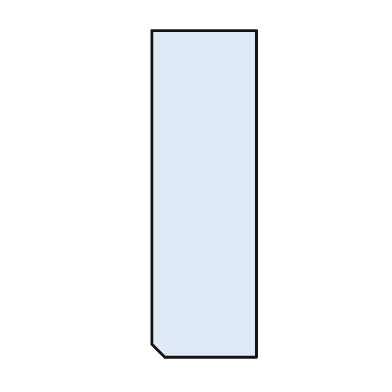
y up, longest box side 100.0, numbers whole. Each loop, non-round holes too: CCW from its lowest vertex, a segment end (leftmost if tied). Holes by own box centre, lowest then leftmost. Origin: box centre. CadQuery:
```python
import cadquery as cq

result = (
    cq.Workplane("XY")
    .moveTo(-12.0, -50.0)
    .lineTo(16.0, -50.0)
    .lineTo(16.0, 50.0)
    .lineTo(-16.0, 50.0)
    .lineTo(-16.0, -46.0)
    .close()
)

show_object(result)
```